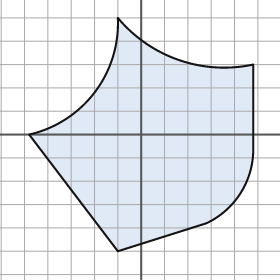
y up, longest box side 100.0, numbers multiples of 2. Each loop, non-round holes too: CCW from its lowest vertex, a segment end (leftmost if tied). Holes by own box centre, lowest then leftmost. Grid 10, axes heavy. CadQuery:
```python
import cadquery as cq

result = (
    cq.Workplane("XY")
    .moveTo(-10.0, -50.0)
    .lineTo(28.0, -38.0)
    .threePointArc((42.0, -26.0), (48.0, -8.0))
    .lineTo(48.0, 30.0)
    .threePointArc((16.0, 32.0), (-10.0, 50.0))
    .threePointArc((-20.0, 18.0), (-48.0, 0.0))
    .close()
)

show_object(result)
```